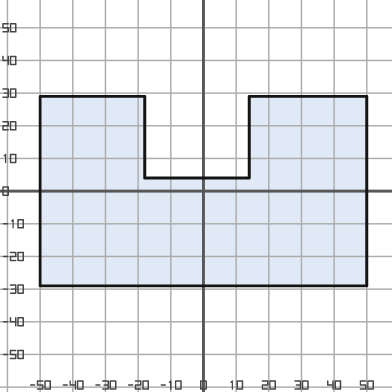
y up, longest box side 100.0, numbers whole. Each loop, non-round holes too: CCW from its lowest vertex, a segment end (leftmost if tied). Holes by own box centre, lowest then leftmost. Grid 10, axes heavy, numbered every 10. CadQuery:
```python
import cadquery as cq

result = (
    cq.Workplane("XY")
    .moveTo(-50.0, -29.0)
    .lineTo(50.0, -29.0)
    .lineTo(50.0, 29.0)
    .lineTo(14.0, 29.0)
    .lineTo(14.0, 4.0)
    .lineTo(-18.0, 4.0)
    .lineTo(-18.0, 29.0)
    .lineTo(-50.0, 29.0)
    .close()
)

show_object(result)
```